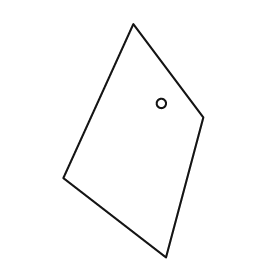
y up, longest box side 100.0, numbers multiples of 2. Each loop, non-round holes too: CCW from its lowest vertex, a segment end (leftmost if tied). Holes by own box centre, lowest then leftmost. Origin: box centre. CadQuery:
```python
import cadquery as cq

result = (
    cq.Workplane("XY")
    .moveTo(14.0, -50.0)
    .lineTo(30.0, 10.0)
    .lineTo(0.0, 50.0)
    .lineTo(-30.0, -16.0)
    .close()
    .moveTo(12.0, 16.0)
    .circle(2.0)
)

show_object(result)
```